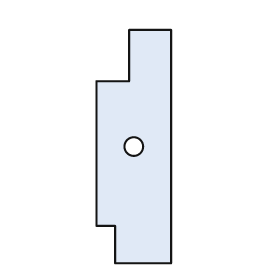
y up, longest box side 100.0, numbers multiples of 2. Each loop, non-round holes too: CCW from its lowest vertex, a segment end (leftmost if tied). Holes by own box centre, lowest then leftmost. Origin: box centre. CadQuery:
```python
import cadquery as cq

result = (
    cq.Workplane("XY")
    .moveTo(-8.0, -50.0)
    .lineTo(16.0, -50.0)
    .lineTo(16.0, 50.0)
    .lineTo(-2.0, 50.0)
    .lineTo(-2.0, 28.0)
    .lineTo(-16.0, 28.0)
    .lineTo(-16.0, -34.0)
    .lineTo(-8.0, -34.0)
    .close()
    .moveTo(0.0, 0.0)
    .circle(4.0)
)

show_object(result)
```